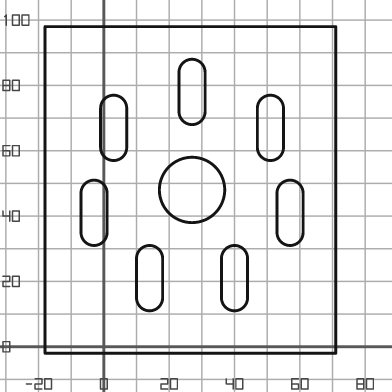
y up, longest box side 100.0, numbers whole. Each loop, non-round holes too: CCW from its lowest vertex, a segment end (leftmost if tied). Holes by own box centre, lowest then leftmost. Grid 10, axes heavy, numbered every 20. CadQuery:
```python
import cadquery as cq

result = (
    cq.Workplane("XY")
    .moveTo(-18.0, -2.0)
    .lineTo(71.0, -2.0)
    .lineTo(71.0, 98.0)
    .lineTo(-18.0, 98.0)
    .close()
    .moveTo(10.0, 15.0)
    .threePointArc((14.0, 11.0), (18.0, 15.0))
    .lineTo(18.0, 27.0)
    .threePointArc((14.0, 31.0), (10.0, 27.0))
    .close()
    .moveTo(36.0, 15.0)
    .threePointArc((40.0, 11.0), (44.0, 15.0))
    .lineTo(44.0, 27.0)
    .threePointArc((40.0, 31.0), (36.0, 27.0))
    .close()
    .moveTo(-7.0, 35.0)
    .threePointArc((-3.0, 31.0), (1.0, 35.0))
    .lineTo(1.0, 47.0)
    .threePointArc((-3.0, 51.0), (-7.0, 47.0))
    .close()
    .moveTo(53.0, 35.0)
    .threePointArc((57.0, 31.0), (61.0, 35.0))
    .lineTo(61.0, 47.0)
    .threePointArc((57.0, 51.0), (53.0, 47.0))
    .close()
    .moveTo(27.0, 48.0)
    .circle(10.0)
    .moveTo(-1.0, 61.0)
    .threePointArc((3.0, 57.0), (7.0, 61.0))
    .lineTo(7.0, 73.0)
    .threePointArc((3.0, 77.0), (-1.0, 73.0))
    .close()
    .moveTo(47.0, 61.0)
    .threePointArc((51.0, 57.0), (55.0, 61.0))
    .lineTo(55.0, 73.0)
    .threePointArc((51.0, 77.0), (47.0, 73.0))
    .close()
    .moveTo(23.0, 72.0)
    .threePointArc((27.0, 68.0), (31.0, 72.0))
    .lineTo(31.0, 84.0)
    .threePointArc((27.0, 88.0), (23.0, 84.0))
    .close()
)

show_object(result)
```